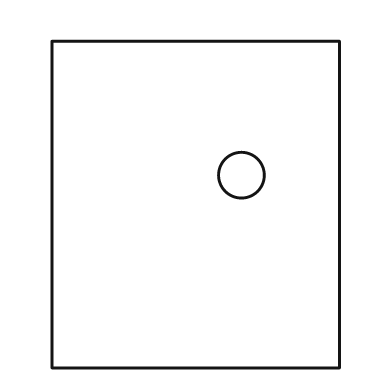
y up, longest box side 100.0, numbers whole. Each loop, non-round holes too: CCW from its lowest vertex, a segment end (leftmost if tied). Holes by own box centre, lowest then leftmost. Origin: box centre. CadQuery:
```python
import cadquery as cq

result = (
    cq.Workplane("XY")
    .moveTo(-44.0, -50.0)
    .lineTo(44.0, -50.0)
    .lineTo(44.0, 50.0)
    .lineTo(-44.0, 50.0)
    .close()
    .moveTo(14.0, 9.0)
    .circle(7.0)
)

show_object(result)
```